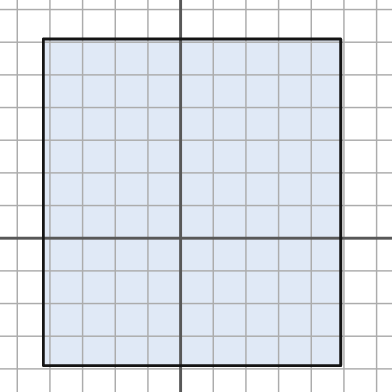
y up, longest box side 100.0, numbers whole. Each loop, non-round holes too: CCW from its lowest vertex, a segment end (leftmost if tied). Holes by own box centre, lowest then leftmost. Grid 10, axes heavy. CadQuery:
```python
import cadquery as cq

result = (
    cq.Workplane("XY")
    .moveTo(-42.0, -39.0)
    .lineTo(49.0, -39.0)
    .lineTo(49.0, 61.0)
    .lineTo(-42.0, 61.0)
    .close()
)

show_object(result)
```